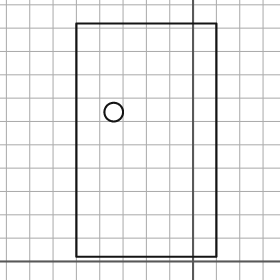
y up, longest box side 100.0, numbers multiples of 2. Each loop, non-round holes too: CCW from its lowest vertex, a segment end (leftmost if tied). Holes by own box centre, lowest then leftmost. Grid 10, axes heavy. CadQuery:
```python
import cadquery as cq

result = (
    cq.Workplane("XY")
    .moveTo(-50.0, 2.0)
    .lineTo(10.0, 2.0)
    .lineTo(10.0, 102.0)
    .lineTo(-50.0, 102.0)
    .close()
    .moveTo(-34.0, 64.0)
    .circle(4.0)
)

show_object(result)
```